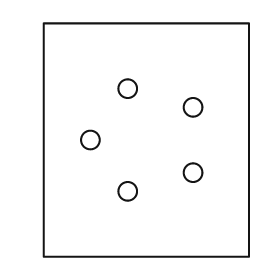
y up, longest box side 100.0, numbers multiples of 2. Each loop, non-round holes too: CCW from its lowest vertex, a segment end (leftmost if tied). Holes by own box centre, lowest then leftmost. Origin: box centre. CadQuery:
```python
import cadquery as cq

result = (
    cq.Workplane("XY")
    .moveTo(-44.0, -50.0)
    .lineTo(44.0, -50.0)
    .lineTo(44.0, 50.0)
    .lineTo(-44.0, 50.0)
    .close()
    .moveTo(-8.0, -22.0)
    .circle(4.0)
    .moveTo(20.0, -14.0)
    .circle(4.0)
    .moveTo(-24.0, 0.0)
    .circle(4.0)
    .moveTo(20.0, 14.0)
    .circle(4.0)
    .moveTo(-8.0, 22.0)
    .circle(4.0)
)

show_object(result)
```